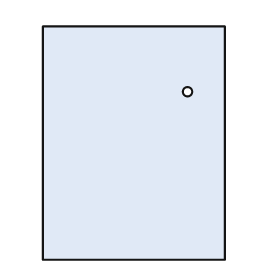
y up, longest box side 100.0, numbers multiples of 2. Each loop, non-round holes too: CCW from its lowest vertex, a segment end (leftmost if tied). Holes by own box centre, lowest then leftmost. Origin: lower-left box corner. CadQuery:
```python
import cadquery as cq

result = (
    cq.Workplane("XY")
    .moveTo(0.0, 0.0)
    .lineTo(78.0, 0.0)
    .lineTo(78.0, 100.0)
    .lineTo(0.0, 100.0)
    .close()
    .moveTo(62.0, 72.0)
    .circle(2.0)
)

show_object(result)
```